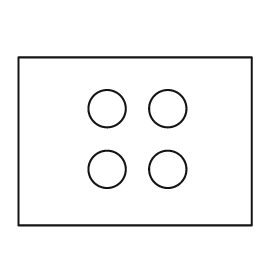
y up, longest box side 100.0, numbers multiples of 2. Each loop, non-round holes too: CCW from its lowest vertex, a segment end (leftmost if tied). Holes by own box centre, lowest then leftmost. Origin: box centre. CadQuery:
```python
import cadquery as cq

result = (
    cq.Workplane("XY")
    .moveTo(-50.0, -36.0)
    .lineTo(50.0, -36.0)
    .lineTo(50.0, 36.0)
    .lineTo(-50.0, 36.0)
    .close()
    .moveTo(-12.0, -12.0)
    .circle(8.0)
    .moveTo(14.0, -12.0)
    .circle(8.0)
    .moveTo(-12.0, 14.0)
    .circle(8.0)
    .moveTo(14.0, 14.0)
    .circle(8.0)
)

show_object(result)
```